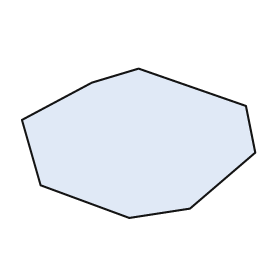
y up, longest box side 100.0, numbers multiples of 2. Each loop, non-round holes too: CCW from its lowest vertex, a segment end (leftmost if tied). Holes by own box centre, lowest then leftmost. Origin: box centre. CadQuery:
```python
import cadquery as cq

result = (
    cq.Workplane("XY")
    .moveTo(-4.0, -32.0)
    .lineTo(22.0, -28.0)
    .lineTo(50.0, -4.0)
    .lineTo(46.0, 16.0)
    .lineTo(0.0, 32.0)
    .lineTo(-20.0, 26.0)
    .lineTo(-50.0, 10.0)
    .lineTo(-42.0, -18.0)
    .close()
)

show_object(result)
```